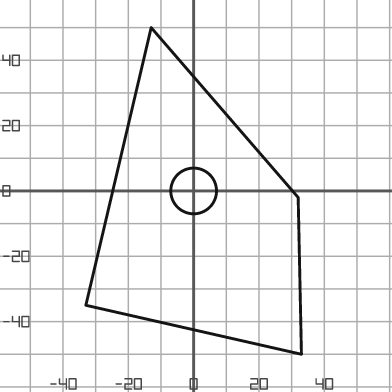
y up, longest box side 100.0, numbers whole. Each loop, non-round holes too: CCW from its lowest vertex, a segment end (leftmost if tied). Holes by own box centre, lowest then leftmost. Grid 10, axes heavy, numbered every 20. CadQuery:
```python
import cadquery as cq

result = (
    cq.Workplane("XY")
    .moveTo(33.0, -50.0)
    .lineTo(32.0, -2.0)
    .lineTo(-13.0, 50.0)
    .lineTo(-33.0, -35.0)
    .close()
    .moveTo(0.0, 0.0)
    .circle(7.0)
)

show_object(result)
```